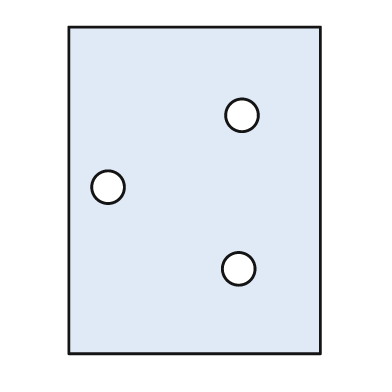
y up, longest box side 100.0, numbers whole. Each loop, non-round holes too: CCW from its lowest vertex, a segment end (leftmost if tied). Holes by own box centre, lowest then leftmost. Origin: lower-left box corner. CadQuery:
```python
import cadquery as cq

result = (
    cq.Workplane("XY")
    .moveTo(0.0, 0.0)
    .lineTo(77.0, 0.0)
    .lineTo(77.0, 100.0)
    .lineTo(0.0, 100.0)
    .close()
    .moveTo(52.0, 26.0)
    .circle(5.0)
    .moveTo(12.0, 51.0)
    .circle(5.0)
    .moveTo(53.0, 73.0)
    .circle(5.0)
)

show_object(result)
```